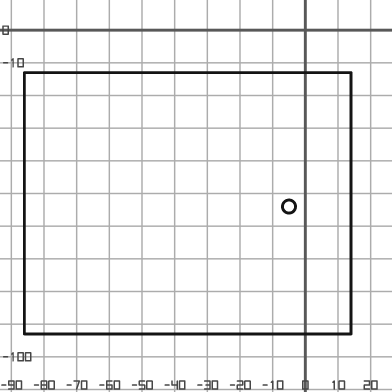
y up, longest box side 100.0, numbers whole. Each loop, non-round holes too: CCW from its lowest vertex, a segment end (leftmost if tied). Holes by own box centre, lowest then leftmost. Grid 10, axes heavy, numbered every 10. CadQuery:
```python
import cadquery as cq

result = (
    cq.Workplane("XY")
    .moveTo(-86.0, -93.0)
    .lineTo(14.0, -93.0)
    .lineTo(14.0, -13.0)
    .lineTo(-86.0, -13.0)
    .close()
    .moveTo(-5.0, -54.0)
    .circle(2.0)
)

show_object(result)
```